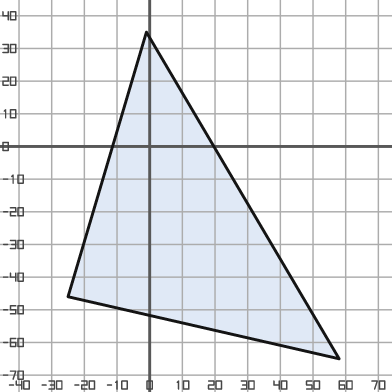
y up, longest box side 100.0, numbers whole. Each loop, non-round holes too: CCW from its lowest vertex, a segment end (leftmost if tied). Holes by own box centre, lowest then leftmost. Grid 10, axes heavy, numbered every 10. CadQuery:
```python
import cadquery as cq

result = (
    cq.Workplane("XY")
    .moveTo(58.0, -65.0)
    .lineTo(-1.0, 35.0)
    .lineTo(-25.0, -46.0)
    .close()
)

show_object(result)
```